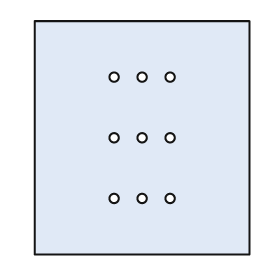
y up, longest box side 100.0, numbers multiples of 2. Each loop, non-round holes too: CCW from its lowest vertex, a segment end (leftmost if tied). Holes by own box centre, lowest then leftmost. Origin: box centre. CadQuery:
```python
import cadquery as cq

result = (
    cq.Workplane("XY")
    .moveTo(-46.0, -50.0)
    .lineTo(46.0, -50.0)
    .lineTo(46.0, 50.0)
    .lineTo(-46.0, 50.0)
    .close()
    .moveTo(-12.0, -26.0)
    .circle(2.0)
    .moveTo(0.0, -26.0)
    .circle(2.0)
    .moveTo(12.0, -26.0)
    .circle(2.0)
    .moveTo(-12.0, 0.0)
    .circle(2.0)
    .moveTo(0.0, 0.0)
    .circle(2.0)
    .moveTo(12.0, 0.0)
    .circle(2.0)
    .moveTo(-12.0, 26.0)
    .circle(2.0)
    .moveTo(0.0, 26.0)
    .circle(2.0)
    .moveTo(12.0, 26.0)
    .circle(2.0)
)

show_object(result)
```